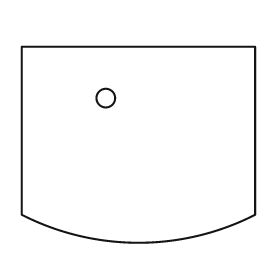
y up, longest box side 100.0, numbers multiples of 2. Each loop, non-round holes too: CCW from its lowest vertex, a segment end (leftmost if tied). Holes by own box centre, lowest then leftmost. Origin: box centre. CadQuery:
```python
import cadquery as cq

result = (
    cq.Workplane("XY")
    .moveTo(-50.0, -30.0)
    .threePointArc((0.0, -42.0), (50.0, -30.0))
    .lineTo(50.0, 42.0)
    .lineTo(-50.0, 42.0)
    .close()
    .moveTo(-14.0, 20.0)
    .circle(4.0)
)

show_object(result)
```